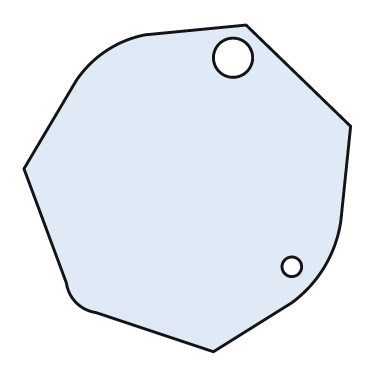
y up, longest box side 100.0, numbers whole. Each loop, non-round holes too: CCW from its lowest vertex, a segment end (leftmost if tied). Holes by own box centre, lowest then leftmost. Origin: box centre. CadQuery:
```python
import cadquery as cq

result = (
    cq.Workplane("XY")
    .moveTo(8.0, -50.0)
    .lineTo(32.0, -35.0)
    .threePointArc((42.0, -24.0), (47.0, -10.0))
    .lineTo(50.0, 19.0)
    .lineTo(18.0, 50.0)
    .lineTo(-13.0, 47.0)
    .threePointArc((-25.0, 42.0), (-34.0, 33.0))
    .lineTo(-50.0, 6.0)
    .lineTo(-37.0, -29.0)
    .threePointArc((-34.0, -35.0), (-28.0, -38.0))
    .close()
    .moveTo(32.0, -24.0)
    .circle(3.0)
    .moveTo(14.0, 40.0)
    .circle(6.0)
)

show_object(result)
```